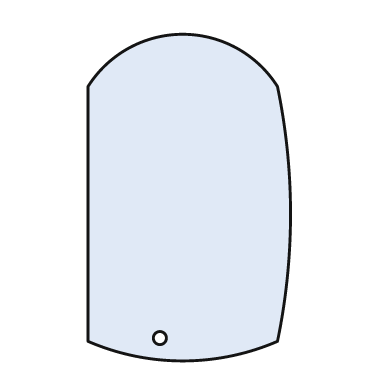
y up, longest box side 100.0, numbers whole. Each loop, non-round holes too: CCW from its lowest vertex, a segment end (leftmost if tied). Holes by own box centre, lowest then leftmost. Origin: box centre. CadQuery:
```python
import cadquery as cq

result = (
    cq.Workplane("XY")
    .moveTo(-31.0, -44.0)
    .threePointArc((-2.0, -50.0), (27.0, -44.0))
    .threePointArc((31.0, -5.0), (27.0, 34.0))
    .threePointArc((-2.0, 50.0), (-31.0, 34.0))
    .close()
    .moveTo(-9.0, -43.0)
    .circle(2.0)
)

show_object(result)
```